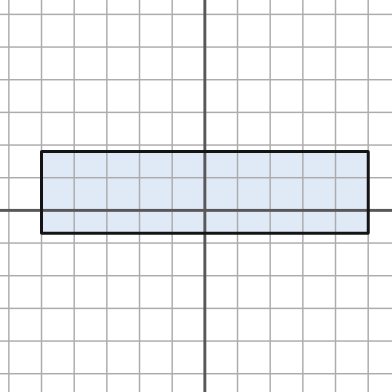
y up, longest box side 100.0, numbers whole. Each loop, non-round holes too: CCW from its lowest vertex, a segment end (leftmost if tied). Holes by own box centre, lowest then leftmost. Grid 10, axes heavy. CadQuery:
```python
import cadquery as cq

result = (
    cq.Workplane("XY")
    .moveTo(-50.0, -7.0)
    .lineTo(50.0, -7.0)
    .lineTo(50.0, 18.0)
    .lineTo(-50.0, 18.0)
    .close()
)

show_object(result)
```